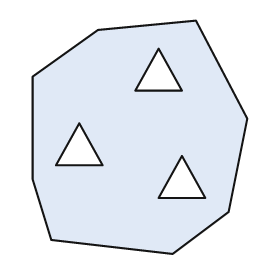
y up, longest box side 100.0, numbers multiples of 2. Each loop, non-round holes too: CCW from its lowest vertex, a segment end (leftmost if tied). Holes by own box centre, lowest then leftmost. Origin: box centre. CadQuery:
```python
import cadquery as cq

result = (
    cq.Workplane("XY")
    .moveTo(14.0, -50.0)
    .lineTo(38.0, -32.0)
    .lineTo(46.0, 8.0)
    .lineTo(24.0, 50.0)
    .lineTo(-18.0, 46.0)
    .lineTo(-46.0, 26.0)
    .lineTo(-46.0, -18.0)
    .lineTo(-38.0, -44.0)
    .close()
    .moveTo(8.0, -26.0)
    .lineTo(28.0, -26.0)
    .lineTo(18.0, -8.0)
    .close()
    .moveTo(-36.0, -12.0)
    .lineTo(-16.0, -12.0)
    .lineTo(-26.0, 6.0)
    .close()
    .moveTo(-2.0, 20.0)
    .lineTo(18.0, 20.0)
    .lineTo(8.0, 38.0)
    .close()
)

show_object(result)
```